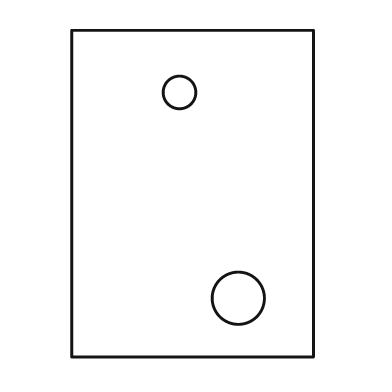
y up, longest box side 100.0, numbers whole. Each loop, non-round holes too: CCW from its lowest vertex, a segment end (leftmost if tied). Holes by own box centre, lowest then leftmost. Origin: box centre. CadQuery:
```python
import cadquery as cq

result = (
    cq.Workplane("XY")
    .moveTo(-37.0, -50.0)
    .lineTo(37.0, -50.0)
    .lineTo(37.0, 50.0)
    .lineTo(-37.0, 50.0)
    .close()
    .moveTo(14.0, -32.0)
    .circle(8.0)
    .moveTo(-4.0, 31.0)
    .circle(5.0)
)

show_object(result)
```